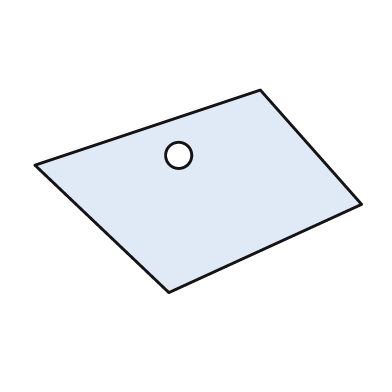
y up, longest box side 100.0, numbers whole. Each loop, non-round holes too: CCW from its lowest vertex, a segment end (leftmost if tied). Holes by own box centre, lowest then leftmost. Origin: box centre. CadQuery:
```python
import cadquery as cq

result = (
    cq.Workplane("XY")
    .moveTo(-9.0, -31.0)
    .lineTo(50.0, -4.0)
    .lineTo(19.0, 31.0)
    .lineTo(-50.0, 8.0)
    .close()
    .moveTo(-6.0, 11.0)
    .circle(4.0)
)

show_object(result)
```